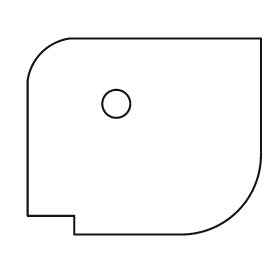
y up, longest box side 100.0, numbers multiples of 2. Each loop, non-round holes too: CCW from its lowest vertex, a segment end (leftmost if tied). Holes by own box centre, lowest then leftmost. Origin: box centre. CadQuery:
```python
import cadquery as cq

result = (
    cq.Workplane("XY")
    .moveTo(-30.0, -42.0)
    .lineTo(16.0, -42.0)
    .threePointArc((40.0, -32.0), (50.0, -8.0))
    .lineTo(50.0, 42.0)
    .lineTo(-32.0, 42.0)
    .threePointArc((-44.0, 36.0), (-50.0, 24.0))
    .lineTo(-50.0, -34.0)
    .lineTo(-30.0, -34.0)
    .close()
    .moveTo(-12.0, 14.0)
    .circle(6.0)
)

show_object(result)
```